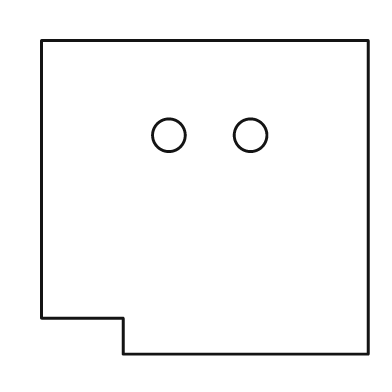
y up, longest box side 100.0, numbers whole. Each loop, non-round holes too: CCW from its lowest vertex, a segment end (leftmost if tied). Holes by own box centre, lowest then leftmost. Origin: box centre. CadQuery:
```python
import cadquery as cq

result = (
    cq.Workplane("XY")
    .moveTo(-25.0, -48.0)
    .lineTo(50.0, -48.0)
    .lineTo(50.0, 48.0)
    .lineTo(-50.0, 48.0)
    .lineTo(-50.0, -37.0)
    .lineTo(-25.0, -37.0)
    .close()
    .moveTo(-11.0, 19.0)
    .circle(5.0)
    .moveTo(14.0, 19.0)
    .circle(5.0)
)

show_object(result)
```